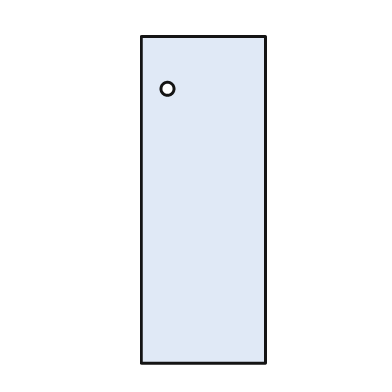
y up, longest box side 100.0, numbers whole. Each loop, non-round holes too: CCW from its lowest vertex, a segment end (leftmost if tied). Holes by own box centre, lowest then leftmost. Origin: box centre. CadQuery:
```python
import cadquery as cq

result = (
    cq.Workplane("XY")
    .moveTo(-19.0, -50.0)
    .lineTo(19.0, -50.0)
    .lineTo(19.0, 50.0)
    .lineTo(-19.0, 50.0)
    .close()
    .moveTo(-11.0, 34.0)
    .circle(2.0)
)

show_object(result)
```